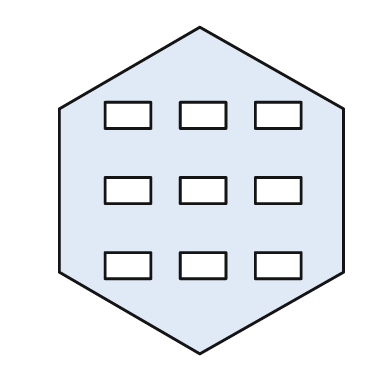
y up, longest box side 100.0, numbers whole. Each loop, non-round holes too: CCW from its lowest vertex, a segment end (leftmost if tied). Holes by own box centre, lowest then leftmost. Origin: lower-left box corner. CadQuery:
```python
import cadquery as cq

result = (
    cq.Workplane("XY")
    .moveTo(43.0, 0.0)
    .lineTo(87.0, 25.0)
    .lineTo(87.0, 75.0)
    .lineTo(43.0, 100.0)
    .lineTo(0.0, 75.0)
    .lineTo(0.0, 25.0)
    .close()
    .moveTo(14.0, 23.0)
    .lineTo(28.0, 23.0)
    .lineTo(28.0, 31.0)
    .lineTo(14.0, 31.0)
    .close()
    .moveTo(37.0, 23.0)
    .lineTo(51.0, 23.0)
    .lineTo(51.0, 31.0)
    .lineTo(37.0, 31.0)
    .close()
    .moveTo(60.0, 23.0)
    .lineTo(74.0, 23.0)
    .lineTo(74.0, 31.0)
    .lineTo(60.0, 31.0)
    .close()
    .moveTo(14.0, 46.0)
    .lineTo(28.0, 46.0)
    .lineTo(28.0, 54.0)
    .lineTo(14.0, 54.0)
    .close()
    .moveTo(37.0, 46.0)
    .lineTo(51.0, 46.0)
    .lineTo(51.0, 54.0)
    .lineTo(37.0, 54.0)
    .close()
    .moveTo(60.0, 46.0)
    .lineTo(74.0, 46.0)
    .lineTo(74.0, 54.0)
    .lineTo(60.0, 54.0)
    .close()
    .moveTo(14.0, 69.0)
    .lineTo(28.0, 69.0)
    .lineTo(28.0, 77.0)
    .lineTo(14.0, 77.0)
    .close()
    .moveTo(37.0, 69.0)
    .lineTo(51.0, 69.0)
    .lineTo(51.0, 77.0)
    .lineTo(37.0, 77.0)
    .close()
    .moveTo(60.0, 69.0)
    .lineTo(74.0, 69.0)
    .lineTo(74.0, 77.0)
    .lineTo(60.0, 77.0)
    .close()
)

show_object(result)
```